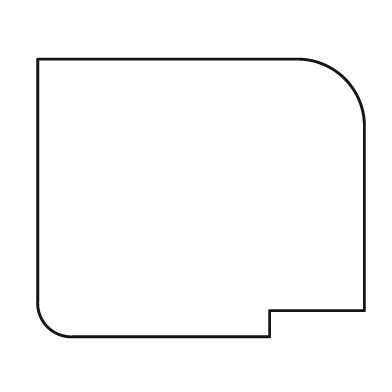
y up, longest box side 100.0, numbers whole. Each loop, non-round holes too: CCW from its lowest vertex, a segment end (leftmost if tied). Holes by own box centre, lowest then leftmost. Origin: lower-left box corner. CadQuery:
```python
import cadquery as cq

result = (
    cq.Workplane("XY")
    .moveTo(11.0, 0.0)
    .lineTo(71.0, 0.0)
    .lineTo(71.0, 8.0)
    .lineTo(100.0, 8.0)
    .lineTo(100.0, 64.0)
    .threePointArc((94.0, 79.0), (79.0, 85.0))
    .lineTo(0.0, 85.0)
    .lineTo(0.0, 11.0)
    .threePointArc((3.0, 3.0), (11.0, 0.0))
    .close()
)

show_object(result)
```